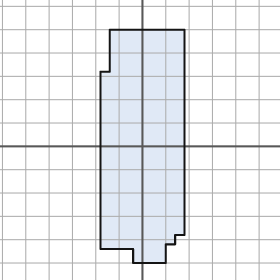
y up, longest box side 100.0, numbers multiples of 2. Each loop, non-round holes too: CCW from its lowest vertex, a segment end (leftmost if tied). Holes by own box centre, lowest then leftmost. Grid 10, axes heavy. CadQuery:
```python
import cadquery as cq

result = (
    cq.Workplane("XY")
    .moveTo(-4.0, -50.0)
    .lineTo(10.0, -50.0)
    .lineTo(10.0, -42.0)
    .lineTo(14.0, -42.0)
    .lineTo(14.0, -38.0)
    .lineTo(18.0, -38.0)
    .lineTo(18.0, 50.0)
    .lineTo(-14.0, 50.0)
    .lineTo(-14.0, 32.0)
    .lineTo(-18.0, 32.0)
    .lineTo(-18.0, -44.0)
    .lineTo(-4.0, -44.0)
    .close()
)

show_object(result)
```